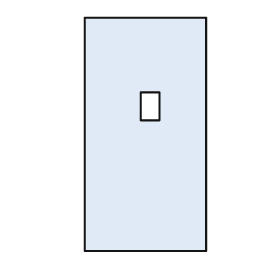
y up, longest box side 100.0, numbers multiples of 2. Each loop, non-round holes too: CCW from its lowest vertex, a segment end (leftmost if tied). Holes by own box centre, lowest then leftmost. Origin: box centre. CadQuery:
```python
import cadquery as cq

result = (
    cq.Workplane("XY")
    .moveTo(-26.0, -50.0)
    .lineTo(26.0, -50.0)
    .lineTo(26.0, 50.0)
    .lineTo(-26.0, 50.0)
    .close()
    .moveTo(-2.0, 6.0)
    .lineTo(6.0, 6.0)
    .lineTo(6.0, 18.0)
    .lineTo(-2.0, 18.0)
    .close()
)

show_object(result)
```